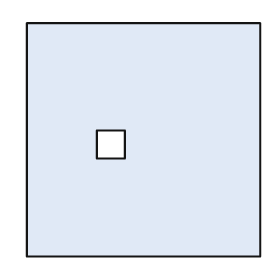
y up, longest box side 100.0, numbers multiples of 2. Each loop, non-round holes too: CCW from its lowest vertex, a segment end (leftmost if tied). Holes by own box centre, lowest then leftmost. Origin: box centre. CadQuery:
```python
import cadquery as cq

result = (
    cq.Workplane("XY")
    .moveTo(-50.0, -50.0)
    .lineTo(50.0, -50.0)
    .lineTo(50.0, 50.0)
    .lineTo(-50.0, 50.0)
    .close()
    .moveTo(-20.0, -8.0)
    .lineTo(-8.0, -8.0)
    .lineTo(-8.0, 4.0)
    .lineTo(-20.0, 4.0)
    .close()
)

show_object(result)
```